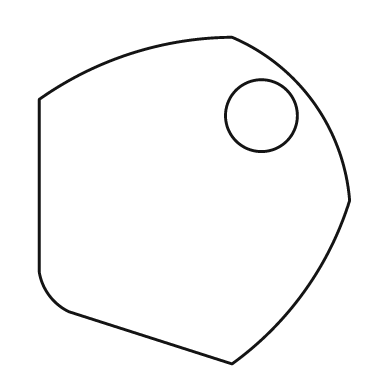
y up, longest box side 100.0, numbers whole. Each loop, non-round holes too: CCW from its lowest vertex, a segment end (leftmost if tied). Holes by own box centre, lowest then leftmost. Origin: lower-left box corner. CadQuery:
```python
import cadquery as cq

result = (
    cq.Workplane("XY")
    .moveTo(59.0, 0.0)
    .threePointArc((81.0, 22.0), (95.0, 50.0))
    .threePointArc((84.0, 80.0), (59.0, 100.0))
    .threePointArc((28.0, 95.0), (0.0, 81.0))
    .lineTo(0.0, 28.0)
    .threePointArc((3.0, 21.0), (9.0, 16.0))
    .close()
    .moveTo(68.0, 76.0)
    .circle(11.0)
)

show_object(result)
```